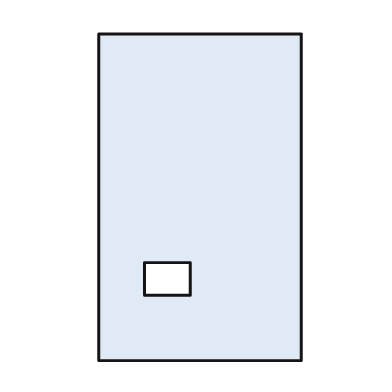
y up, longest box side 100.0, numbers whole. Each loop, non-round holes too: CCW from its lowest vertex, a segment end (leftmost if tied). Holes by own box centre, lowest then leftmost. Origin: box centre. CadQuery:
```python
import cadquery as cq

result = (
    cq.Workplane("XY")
    .moveTo(-31.0, -50.0)
    .lineTo(31.0, -50.0)
    .lineTo(31.0, 50.0)
    .lineTo(-31.0, 50.0)
    .close()
    .moveTo(-17.0, -30.0)
    .lineTo(-3.0, -30.0)
    .lineTo(-3.0, -20.0)
    .lineTo(-17.0, -20.0)
    .close()
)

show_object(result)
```